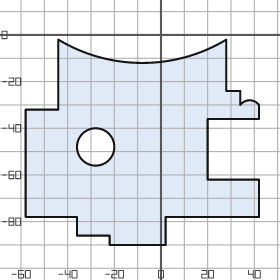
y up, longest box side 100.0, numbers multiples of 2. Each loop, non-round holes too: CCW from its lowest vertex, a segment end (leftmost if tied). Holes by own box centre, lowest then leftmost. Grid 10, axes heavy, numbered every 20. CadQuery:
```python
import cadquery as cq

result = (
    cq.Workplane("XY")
    .moveTo(-22.0, -90.0)
    .lineTo(2.0, -90.0)
    .lineTo(2.0, -78.0)
    .lineTo(42.0, -78.0)
    .lineTo(42.0, -62.0)
    .lineTo(20.0, -62.0)
    .lineTo(20.0, -36.0)
    .lineTo(42.0, -36.0)
    .lineTo(42.0, -30.0)
    .threePointArc((38.0, -28.0), (34.0, -30.0))
    .lineTo(34.0, -24.0)
    .lineTo(28.0, -24.0)
    .lineTo(28.0, -2.0)
    .threePointArc((-8.0, -12.0), (-44.0, -2.0))
    .lineTo(-44.0, -32.0)
    .lineTo(-58.0, -32.0)
    .lineTo(-58.0, -78.0)
    .lineTo(-36.0, -78.0)
    .lineTo(-36.0, -86.0)
    .lineTo(-22.0, -86.0)
    .close()
    .moveTo(-28.0, -48.0)
    .circle(8.0)
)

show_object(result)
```